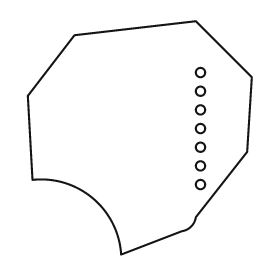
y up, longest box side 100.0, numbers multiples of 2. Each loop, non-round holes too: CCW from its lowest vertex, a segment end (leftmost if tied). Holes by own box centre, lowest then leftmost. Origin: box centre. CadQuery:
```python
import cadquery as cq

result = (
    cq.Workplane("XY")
    .moveTo(-8.0, -50.0)
    .lineTo(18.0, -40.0)
    .threePointArc((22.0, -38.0), (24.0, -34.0))
    .lineTo(46.0, -6.0)
    .lineTo(48.0, 26.0)
    .lineTo(24.0, 50.0)
    .lineTo(-28.0, 44.0)
    .lineTo(-48.0, 18.0)
    .lineTo(-46.0, -18.0)
    .threePointArc((-20.0, -26.0), (-8.0, -50.0))
    .close()
    .moveTo(26.0, -20.0)
    .circle(2.0)
    .moveTo(26.0, -12.0)
    .circle(2.0)
    .moveTo(26.0, -4.0)
    .circle(2.0)
    .moveTo(26.0, 4.0)
    .circle(2.0)
    .moveTo(26.0, 12.0)
    .circle(2.0)
    .moveTo(26.0, 20.0)
    .circle(2.0)
    .moveTo(26.0, 28.0)
    .circle(2.0)
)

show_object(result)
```